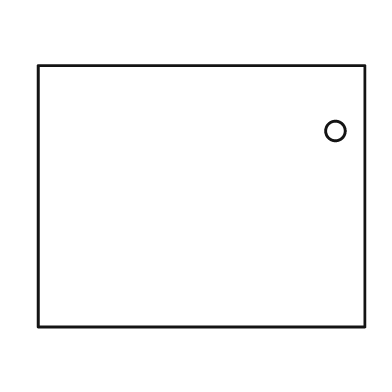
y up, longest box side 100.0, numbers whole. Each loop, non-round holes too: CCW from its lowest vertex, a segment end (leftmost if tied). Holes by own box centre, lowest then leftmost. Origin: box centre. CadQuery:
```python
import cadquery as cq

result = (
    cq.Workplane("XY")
    .moveTo(-50.0, -40.0)
    .lineTo(50.0, -40.0)
    .lineTo(50.0, 40.0)
    .lineTo(-50.0, 40.0)
    .close()
    .moveTo(41.0, 20.0)
    .circle(3.0)
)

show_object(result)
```